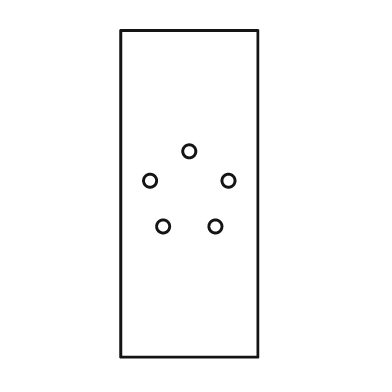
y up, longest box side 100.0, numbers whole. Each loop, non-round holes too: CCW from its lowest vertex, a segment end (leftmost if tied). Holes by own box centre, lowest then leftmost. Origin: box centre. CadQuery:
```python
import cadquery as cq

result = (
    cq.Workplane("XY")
    .moveTo(-21.0, -50.0)
    .lineTo(21.0, -50.0)
    .lineTo(21.0, 50.0)
    .lineTo(-21.0, 50.0)
    .close()
    .moveTo(-8.0, -10.0)
    .circle(2.0)
    .moveTo(8.0, -10.0)
    .circle(2.0)
    .moveTo(-12.0, 4.0)
    .circle(2.0)
    .moveTo(12.0, 4.0)
    .circle(2.0)
    .moveTo(0.0, 13.0)
    .circle(2.0)
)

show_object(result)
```